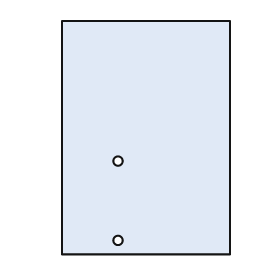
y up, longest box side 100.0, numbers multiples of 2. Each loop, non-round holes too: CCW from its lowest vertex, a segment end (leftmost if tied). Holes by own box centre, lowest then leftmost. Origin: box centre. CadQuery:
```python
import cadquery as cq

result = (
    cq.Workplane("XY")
    .moveTo(-36.0, -50.0)
    .lineTo(36.0, -50.0)
    .lineTo(36.0, 50.0)
    .lineTo(-36.0, 50.0)
    .close()
    .moveTo(-12.0, -44.0)
    .circle(2.0)
    .moveTo(-12.0, -10.0)
    .circle(2.0)
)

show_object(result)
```